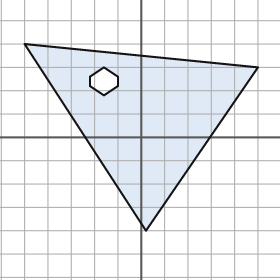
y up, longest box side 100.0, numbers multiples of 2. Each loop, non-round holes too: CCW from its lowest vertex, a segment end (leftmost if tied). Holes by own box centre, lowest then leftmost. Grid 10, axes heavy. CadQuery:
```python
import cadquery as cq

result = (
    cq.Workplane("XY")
    .moveTo(2.0, -40.0)
    .lineTo(50.0, 30.0)
    .lineTo(-50.0, 40.0)
    .close()
    .moveTo(-16.0, 18.0)
    .lineTo(-10.0, 22.0)
    .lineTo(-10.0, 26.0)
    .lineTo(-16.0, 30.0)
    .lineTo(-22.0, 26.0)
    .lineTo(-22.0, 22.0)
    .close()
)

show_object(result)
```